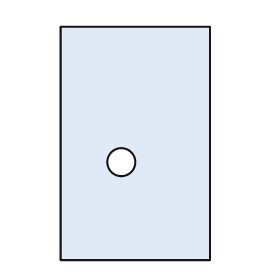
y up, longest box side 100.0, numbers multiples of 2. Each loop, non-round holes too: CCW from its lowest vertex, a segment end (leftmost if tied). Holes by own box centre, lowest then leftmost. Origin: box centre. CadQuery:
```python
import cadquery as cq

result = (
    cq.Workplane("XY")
    .moveTo(-32.0, -50.0)
    .lineTo(32.0, -50.0)
    .lineTo(32.0, 50.0)
    .lineTo(-32.0, 50.0)
    .close()
    .moveTo(-6.0, -8.0)
    .circle(6.0)
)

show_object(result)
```